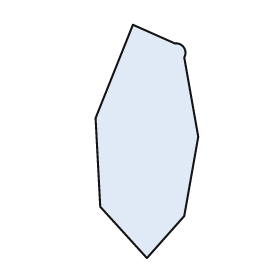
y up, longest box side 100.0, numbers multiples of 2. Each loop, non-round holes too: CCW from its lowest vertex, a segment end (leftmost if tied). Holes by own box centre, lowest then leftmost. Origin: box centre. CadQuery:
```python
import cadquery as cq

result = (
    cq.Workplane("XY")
    .moveTo(0.0, -50.0)
    .lineTo(16.0, -32.0)
    .lineTo(22.0, 2.0)
    .lineTo(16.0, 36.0)
    .threePointArc((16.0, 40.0), (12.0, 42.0))
    .lineTo(-6.0, 50.0)
    .lineTo(-22.0, 10.0)
    .lineTo(-20.0, -28.0)
    .close()
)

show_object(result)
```